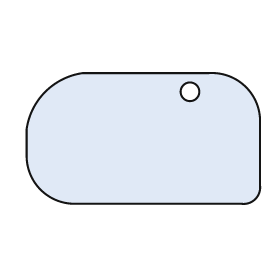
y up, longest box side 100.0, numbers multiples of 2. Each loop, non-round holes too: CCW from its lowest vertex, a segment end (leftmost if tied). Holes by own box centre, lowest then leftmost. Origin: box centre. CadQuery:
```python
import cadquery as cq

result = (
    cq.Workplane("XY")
    .moveTo(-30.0, -28.0)
    .lineTo(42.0, -28.0)
    .threePointArc((48.0, -26.0), (50.0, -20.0))
    .lineTo(50.0, 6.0)
    .threePointArc((44.0, 22.0), (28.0, 28.0))
    .lineTo(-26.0, 28.0)
    .threePointArc((-42.0, 20.0), (-50.0, 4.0))
    .lineTo(-50.0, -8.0)
    .threePointArc((-44.0, -22.0), (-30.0, -28.0))
    .close()
    .moveTo(20.0, 20.0)
    .circle(4.0)
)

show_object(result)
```